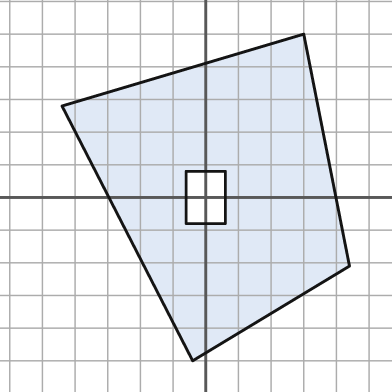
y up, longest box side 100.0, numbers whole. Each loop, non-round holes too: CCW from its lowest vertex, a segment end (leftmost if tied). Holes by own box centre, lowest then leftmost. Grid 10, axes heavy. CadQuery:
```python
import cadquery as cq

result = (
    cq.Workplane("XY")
    .moveTo(-4.0, -50.0)
    .lineTo(44.0, -21.0)
    .lineTo(30.0, 50.0)
    .lineTo(-44.0, 28.0)
    .close()
    .moveTo(-6.0, -8.0)
    .lineTo(6.0, -8.0)
    .lineTo(6.0, 8.0)
    .lineTo(-6.0, 8.0)
    .close()
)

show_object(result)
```